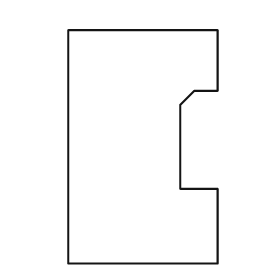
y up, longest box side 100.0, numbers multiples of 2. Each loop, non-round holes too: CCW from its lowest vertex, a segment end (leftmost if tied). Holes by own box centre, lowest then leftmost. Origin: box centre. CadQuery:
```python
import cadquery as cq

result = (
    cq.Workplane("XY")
    .moveTo(-32.0, -50.0)
    .lineTo(32.0, -50.0)
    .lineTo(32.0, -18.0)
    .lineTo(16.0, -18.0)
    .lineTo(16.0, 18.0)
    .lineTo(22.0, 24.0)
    .lineTo(32.0, 24.0)
    .lineTo(32.0, 50.0)
    .lineTo(-32.0, 50.0)
    .close()
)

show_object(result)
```